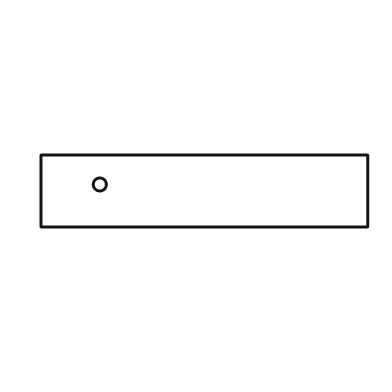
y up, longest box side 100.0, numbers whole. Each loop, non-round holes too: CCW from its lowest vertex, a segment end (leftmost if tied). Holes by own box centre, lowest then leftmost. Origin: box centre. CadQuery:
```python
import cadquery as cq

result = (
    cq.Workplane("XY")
    .moveTo(-50.0, -11.0)
    .lineTo(50.0, -11.0)
    .lineTo(50.0, 11.0)
    .lineTo(-50.0, 11.0)
    .close()
    .moveTo(-32.0, 2.0)
    .circle(2.0)
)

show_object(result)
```